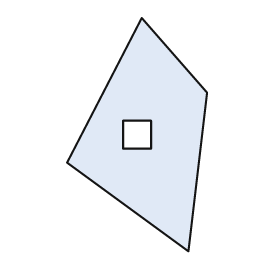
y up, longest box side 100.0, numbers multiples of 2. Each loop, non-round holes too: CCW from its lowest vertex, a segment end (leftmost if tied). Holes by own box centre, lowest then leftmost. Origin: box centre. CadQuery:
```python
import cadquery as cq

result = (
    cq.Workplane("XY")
    .moveTo(22.0, -50.0)
    .lineTo(30.0, 18.0)
    .lineTo(2.0, 50.0)
    .lineTo(-30.0, -12.0)
    .close()
    .moveTo(-6.0, -6.0)
    .lineTo(6.0, -6.0)
    .lineTo(6.0, 6.0)
    .lineTo(-6.0, 6.0)
    .close()
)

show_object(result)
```